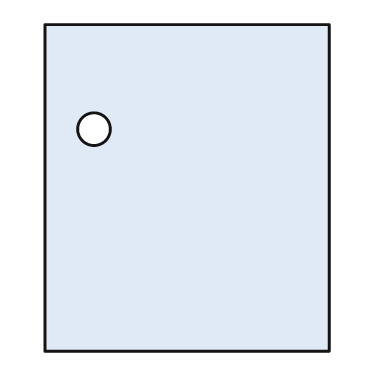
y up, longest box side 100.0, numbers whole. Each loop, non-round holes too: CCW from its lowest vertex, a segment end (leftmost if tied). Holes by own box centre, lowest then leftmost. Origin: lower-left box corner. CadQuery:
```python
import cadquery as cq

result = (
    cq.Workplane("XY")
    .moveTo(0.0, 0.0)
    .lineTo(87.0, 0.0)
    .lineTo(87.0, 100.0)
    .lineTo(0.0, 100.0)
    .close()
    .moveTo(15.0, 68.0)
    .circle(5.0)
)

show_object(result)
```